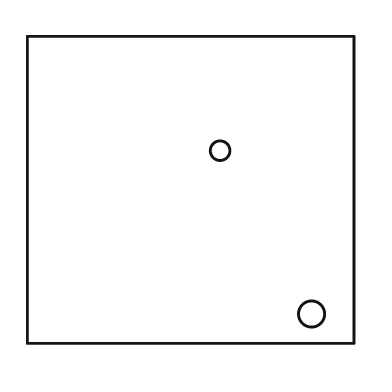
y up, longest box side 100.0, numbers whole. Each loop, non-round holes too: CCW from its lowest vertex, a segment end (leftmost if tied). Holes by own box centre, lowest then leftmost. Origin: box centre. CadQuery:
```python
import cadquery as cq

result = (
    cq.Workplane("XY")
    .moveTo(-50.0, -47.0)
    .lineTo(50.0, -47.0)
    .lineTo(50.0, 47.0)
    .lineTo(-50.0, 47.0)
    .close()
    .moveTo(37.0, -38.0)
    .circle(4.0)
    .moveTo(9.0, 12.0)
    .circle(3.0)
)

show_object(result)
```